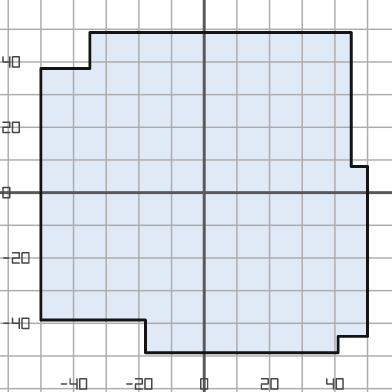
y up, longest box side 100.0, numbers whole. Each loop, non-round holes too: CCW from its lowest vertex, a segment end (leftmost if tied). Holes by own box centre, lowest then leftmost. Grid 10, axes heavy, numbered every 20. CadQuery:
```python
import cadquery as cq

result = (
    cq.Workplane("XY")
    .moveTo(-18.0, -49.0)
    .lineTo(41.0, -49.0)
    .lineTo(41.0, -44.0)
    .lineTo(50.0, -44.0)
    .lineTo(50.0, 8.0)
    .lineTo(45.0, 8.0)
    .lineTo(45.0, 49.0)
    .lineTo(-35.0, 49.0)
    .lineTo(-35.0, 38.0)
    .lineTo(-50.0, 38.0)
    .lineTo(-50.0, -39.0)
    .lineTo(-18.0, -39.0)
    .close()
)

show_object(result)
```